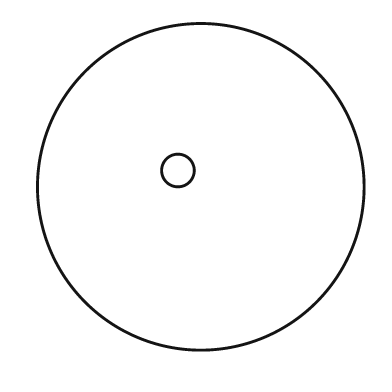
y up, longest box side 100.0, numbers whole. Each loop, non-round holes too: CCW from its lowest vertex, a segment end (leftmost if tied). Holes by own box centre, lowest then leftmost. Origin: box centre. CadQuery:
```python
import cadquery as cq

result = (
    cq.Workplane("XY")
    .moveTo(0.0, 0.0)
    .circle(50.0)
    .moveTo(-7.0, 5.0)
    .circle(5.0)
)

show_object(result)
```